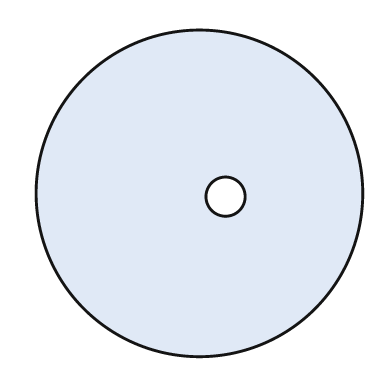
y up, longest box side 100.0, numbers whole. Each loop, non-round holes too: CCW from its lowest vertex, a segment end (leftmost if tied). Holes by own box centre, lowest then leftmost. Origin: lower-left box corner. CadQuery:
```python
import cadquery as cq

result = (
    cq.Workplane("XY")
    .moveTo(50.0, 50.0)
    .circle(50.0)
    .moveTo(58.0, 49.0)
    .circle(6.0)
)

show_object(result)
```